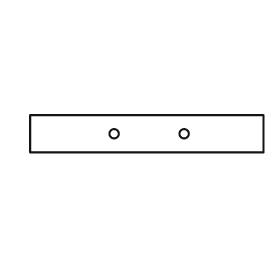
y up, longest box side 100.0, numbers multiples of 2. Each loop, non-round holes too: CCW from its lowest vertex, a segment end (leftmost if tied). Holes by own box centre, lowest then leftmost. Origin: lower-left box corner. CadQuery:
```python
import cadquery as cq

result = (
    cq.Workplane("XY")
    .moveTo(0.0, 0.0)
    .lineTo(100.0, 0.0)
    .lineTo(100.0, 16.0)
    .lineTo(0.0, 16.0)
    .close()
    .moveTo(36.0, 8.0)
    .circle(2.0)
    .moveTo(66.0, 8.0)
    .circle(2.0)
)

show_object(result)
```